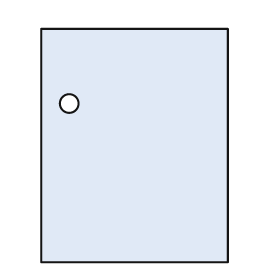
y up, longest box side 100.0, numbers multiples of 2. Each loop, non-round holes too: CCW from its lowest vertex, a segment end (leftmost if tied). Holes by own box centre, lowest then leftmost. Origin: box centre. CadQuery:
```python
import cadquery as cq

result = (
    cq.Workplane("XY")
    .moveTo(-40.0, -50.0)
    .lineTo(40.0, -50.0)
    .lineTo(40.0, 50.0)
    .lineTo(-40.0, 50.0)
    .close()
    .moveTo(-28.0, 18.0)
    .circle(4.0)
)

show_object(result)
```